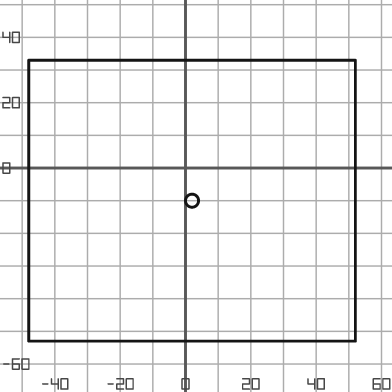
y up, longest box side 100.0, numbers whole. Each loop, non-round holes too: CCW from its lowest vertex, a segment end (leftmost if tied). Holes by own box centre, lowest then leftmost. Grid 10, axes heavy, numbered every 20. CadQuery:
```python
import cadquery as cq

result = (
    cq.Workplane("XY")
    .moveTo(-48.0, -53.0)
    .lineTo(52.0, -53.0)
    .lineTo(52.0, 33.0)
    .lineTo(-48.0, 33.0)
    .close()
    .moveTo(2.0, -10.0)
    .circle(2.0)
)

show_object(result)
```